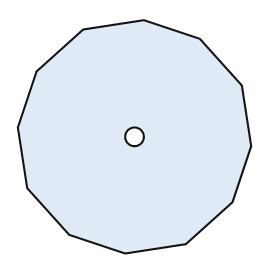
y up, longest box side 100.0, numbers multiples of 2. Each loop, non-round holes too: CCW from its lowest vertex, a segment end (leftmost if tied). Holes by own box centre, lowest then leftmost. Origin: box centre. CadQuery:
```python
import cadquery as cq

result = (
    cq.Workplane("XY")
    .moveTo(-4.0, -50.0)
    .lineTo(22.0, -46.0)
    .lineTo(42.0, -28.0)
    .lineTo(50.0, -4.0)
    .lineTo(46.0, 22.0)
    .lineTo(28.0, 42.0)
    .lineTo(4.0, 50.0)
    .lineTo(-22.0, 46.0)
    .lineTo(-42.0, 28.0)
    .lineTo(-50.0, 4.0)
    .lineTo(-46.0, -22.0)
    .lineTo(-28.0, -42.0)
    .close()
    .moveTo(0.0, 0.0)
    .circle(4.0)
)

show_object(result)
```